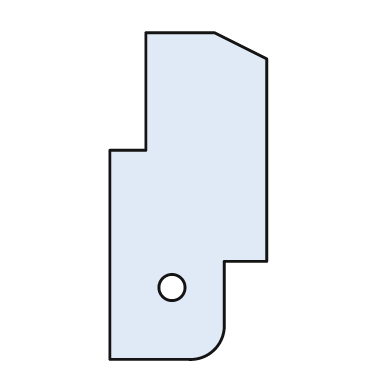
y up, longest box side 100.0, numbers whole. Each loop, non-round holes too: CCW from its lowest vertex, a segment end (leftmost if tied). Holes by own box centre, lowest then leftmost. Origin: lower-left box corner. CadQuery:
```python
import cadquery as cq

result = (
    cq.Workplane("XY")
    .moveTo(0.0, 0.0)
    .lineTo(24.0, 0.0)
    .threePointArc((32.0, 3.0), (35.0, 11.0))
    .lineTo(35.0, 30.0)
    .lineTo(48.0, 30.0)
    .lineTo(48.0, 92.0)
    .lineTo(32.0, 100.0)
    .lineTo(11.0, 100.0)
    .lineTo(11.0, 64.0)
    .lineTo(0.0, 64.0)
    .close()
    .moveTo(19.0, 22.0)
    .circle(4.0)
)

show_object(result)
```